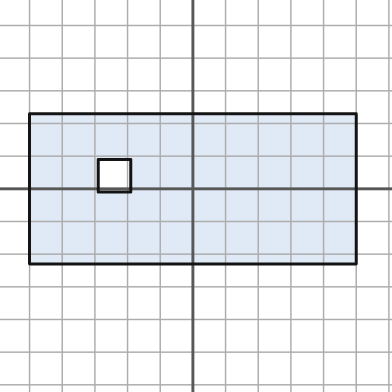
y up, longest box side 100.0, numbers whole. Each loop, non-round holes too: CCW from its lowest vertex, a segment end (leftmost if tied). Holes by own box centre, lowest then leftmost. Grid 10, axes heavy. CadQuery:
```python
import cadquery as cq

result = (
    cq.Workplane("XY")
    .moveTo(-50.0, -23.0)
    .lineTo(50.0, -23.0)
    .lineTo(50.0, 23.0)
    .lineTo(-50.0, 23.0)
    .close()
    .moveTo(-29.0, -1.0)
    .lineTo(-19.0, -1.0)
    .lineTo(-19.0, 9.0)
    .lineTo(-29.0, 9.0)
    .close()
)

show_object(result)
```